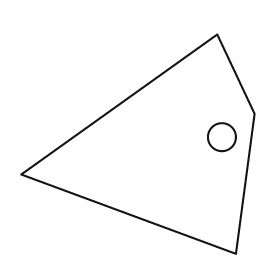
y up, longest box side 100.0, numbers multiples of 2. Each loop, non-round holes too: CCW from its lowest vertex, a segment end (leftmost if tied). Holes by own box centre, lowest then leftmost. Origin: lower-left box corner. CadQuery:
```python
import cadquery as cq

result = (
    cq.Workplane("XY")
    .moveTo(92.0, 0.0)
    .lineTo(100.0, 60.0)
    .lineTo(84.0, 94.0)
    .lineTo(0.0, 34.0)
    .close()
    .moveTo(86.0, 50.0)
    .circle(6.0)
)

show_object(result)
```